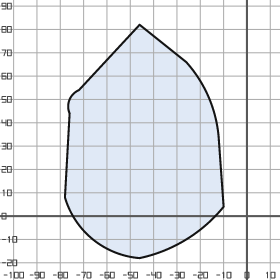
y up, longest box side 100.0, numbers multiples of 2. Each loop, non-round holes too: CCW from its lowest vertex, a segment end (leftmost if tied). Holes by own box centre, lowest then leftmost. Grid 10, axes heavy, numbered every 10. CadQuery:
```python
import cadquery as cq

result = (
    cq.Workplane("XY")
    .moveTo(-46.0, -18.0)
    .threePointArc((-26.0, -10.0), (-10.0, 4.0))
    .lineTo(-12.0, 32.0)
    .threePointArc((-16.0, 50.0), (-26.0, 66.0))
    .lineTo(-46.0, 82.0)
    .lineTo(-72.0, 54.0)
    .threePointArc((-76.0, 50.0), (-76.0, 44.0))
    .lineTo(-78.0, 8.0)
    .threePointArc((-66.0, -10.0), (-46.0, -18.0))
    .close()
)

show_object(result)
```